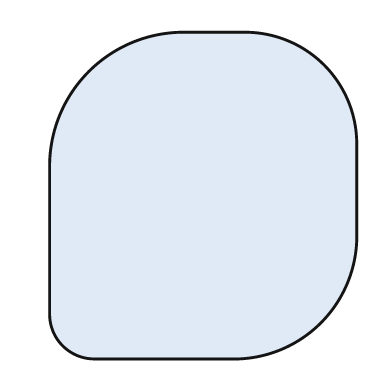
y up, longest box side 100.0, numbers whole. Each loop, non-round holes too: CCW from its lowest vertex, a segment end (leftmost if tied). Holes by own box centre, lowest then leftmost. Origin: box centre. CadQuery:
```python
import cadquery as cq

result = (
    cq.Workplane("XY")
    .moveTo(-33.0, -50.0)
    .lineTo(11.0, -50.0)
    .threePointArc((36.0, -39.0), (47.0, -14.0))
    .lineTo(47.0, 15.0)
    .threePointArc((37.0, 40.0), (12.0, 50.0))
    .lineTo(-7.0, 50.0)
    .threePointArc((-35.0, 38.0), (-47.0, 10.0))
    .lineTo(-47.0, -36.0)
    .threePointArc((-43.0, -46.0), (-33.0, -50.0))
    .close()
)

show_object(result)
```